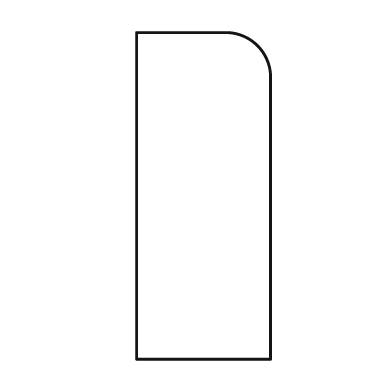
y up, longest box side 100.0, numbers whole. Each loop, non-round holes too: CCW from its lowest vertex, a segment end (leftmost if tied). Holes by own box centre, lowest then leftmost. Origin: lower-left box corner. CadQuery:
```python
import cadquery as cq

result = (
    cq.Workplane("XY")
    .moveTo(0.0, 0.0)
    .lineTo(41.0, 0.0)
    .lineTo(41.0, 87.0)
    .threePointArc((37.0, 96.0), (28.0, 100.0))
    .lineTo(0.0, 100.0)
    .close()
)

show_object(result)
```